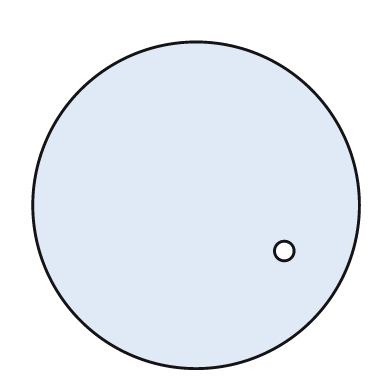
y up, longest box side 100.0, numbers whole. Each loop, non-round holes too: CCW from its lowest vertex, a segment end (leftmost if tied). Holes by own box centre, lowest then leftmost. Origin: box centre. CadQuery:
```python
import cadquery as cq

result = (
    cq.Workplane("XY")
    .moveTo(0.0, 0.0)
    .circle(50.0)
    .moveTo(27.0, -14.0)
    .circle(3.0)
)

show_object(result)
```